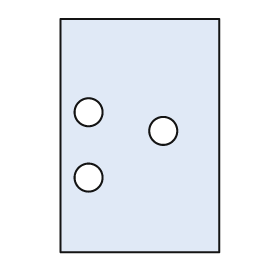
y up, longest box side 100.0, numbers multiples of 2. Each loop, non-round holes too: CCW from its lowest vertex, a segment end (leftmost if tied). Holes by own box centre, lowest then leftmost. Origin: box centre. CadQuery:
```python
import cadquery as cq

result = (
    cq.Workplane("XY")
    .moveTo(-34.0, -50.0)
    .lineTo(34.0, -50.0)
    .lineTo(34.0, 50.0)
    .lineTo(-34.0, 50.0)
    .close()
    .moveTo(-22.0, -18.0)
    .circle(6.0)
    .moveTo(10.0, 2.0)
    .circle(6.0)
    .moveTo(-22.0, 10.0)
    .circle(6.0)
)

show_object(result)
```